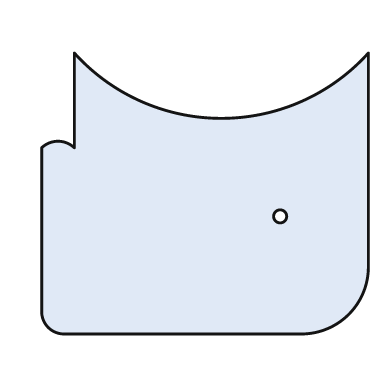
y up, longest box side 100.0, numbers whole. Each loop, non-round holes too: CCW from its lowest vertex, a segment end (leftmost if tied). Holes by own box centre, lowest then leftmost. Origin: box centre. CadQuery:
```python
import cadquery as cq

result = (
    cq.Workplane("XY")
    .moveTo(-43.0, -43.0)
    .lineTo(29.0, -43.0)
    .threePointArc((44.0, -37.0), (50.0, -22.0))
    .lineTo(50.0, 43.0)
    .threePointArc((5.0, 23.0), (-40.0, 43.0))
    .lineTo(-40.0, 14.0)
    .threePointArc((-45.0, 16.0), (-50.0, 14.0))
    .lineTo(-50.0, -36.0)
    .threePointArc((-48.0, -41.0), (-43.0, -43.0))
    .close()
    .moveTo(23.0, -7.0)
    .circle(2.0)
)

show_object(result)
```